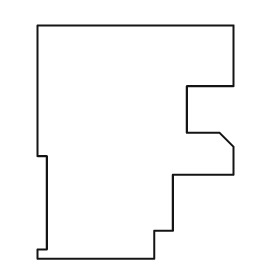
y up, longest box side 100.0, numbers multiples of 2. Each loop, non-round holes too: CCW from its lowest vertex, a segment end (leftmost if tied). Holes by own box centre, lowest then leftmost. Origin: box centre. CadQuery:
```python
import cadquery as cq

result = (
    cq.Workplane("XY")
    .moveTo(-42.0, -50.0)
    .lineTo(8.0, -50.0)
    .lineTo(8.0, -38.0)
    .lineTo(16.0, -38.0)
    .lineTo(16.0, -14.0)
    .lineTo(42.0, -14.0)
    .lineTo(42.0, -2.0)
    .lineTo(36.0, 4.0)
    .lineTo(22.0, 4.0)
    .lineTo(22.0, 24.0)
    .lineTo(42.0, 24.0)
    .lineTo(42.0, 50.0)
    .lineTo(-42.0, 50.0)
    .lineTo(-42.0, -6.0)
    .lineTo(-38.0, -6.0)
    .lineTo(-38.0, -46.0)
    .lineTo(-42.0, -46.0)
    .close()
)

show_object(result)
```